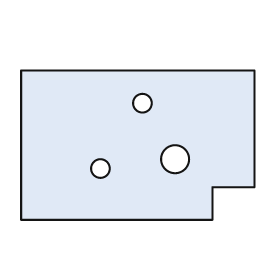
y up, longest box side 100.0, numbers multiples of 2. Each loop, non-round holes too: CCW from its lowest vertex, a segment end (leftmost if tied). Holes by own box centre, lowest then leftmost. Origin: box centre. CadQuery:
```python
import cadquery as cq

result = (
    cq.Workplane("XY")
    .moveTo(-50.0, -32.0)
    .lineTo(32.0, -32.0)
    .lineTo(32.0, -18.0)
    .lineTo(50.0, -18.0)
    .lineTo(50.0, 32.0)
    .lineTo(-50.0, 32.0)
    .close()
    .moveTo(-16.0, -10.0)
    .circle(4.0)
    .moveTo(16.0, -6.0)
    .circle(6.0)
    .moveTo(2.0, 18.0)
    .circle(4.0)
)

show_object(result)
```